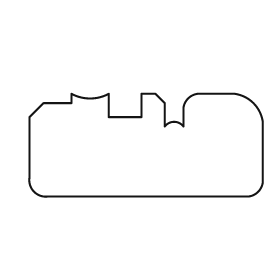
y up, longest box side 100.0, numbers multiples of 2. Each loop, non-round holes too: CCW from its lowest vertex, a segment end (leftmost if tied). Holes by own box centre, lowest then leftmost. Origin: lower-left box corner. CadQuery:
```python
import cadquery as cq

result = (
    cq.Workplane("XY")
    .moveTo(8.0, 0.0)
    .lineTo(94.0, 0.0)
    .threePointArc((98.0, 2.0), (100.0, 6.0))
    .lineTo(100.0, 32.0)
    .threePointArc((96.0, 40.0), (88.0, 44.0))
    .lineTo(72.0, 44.0)
    .threePointArc((68.0, 42.0), (66.0, 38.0))
    .lineTo(66.0, 30.0)
    .threePointArc((62.0, 32.0), (58.0, 30.0))
    .lineTo(58.0, 40.0)
    .lineTo(54.0, 44.0)
    .lineTo(48.0, 44.0)
    .lineTo(48.0, 34.0)
    .lineTo(34.0, 34.0)
    .lineTo(34.0, 44.0)
    .threePointArc((26.0, 42.0), (18.0, 44.0))
    .lineTo(18.0, 40.0)
    .lineTo(6.0, 40.0)
    .lineTo(0.0, 34.0)
    .lineTo(0.0, 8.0)
    .threePointArc((2.0, 2.0), (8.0, 0.0))
    .close()
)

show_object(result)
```